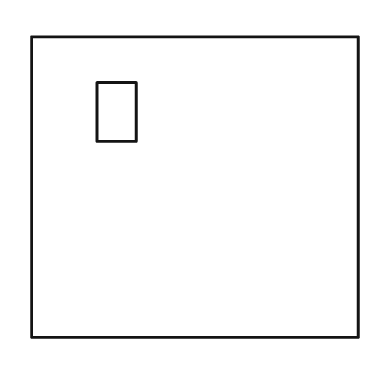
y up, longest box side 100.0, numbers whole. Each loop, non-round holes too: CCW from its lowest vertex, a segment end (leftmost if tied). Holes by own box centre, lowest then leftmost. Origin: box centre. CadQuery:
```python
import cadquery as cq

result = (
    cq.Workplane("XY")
    .moveTo(-50.0, -46.0)
    .lineTo(50.0, -46.0)
    .lineTo(50.0, 46.0)
    .lineTo(-50.0, 46.0)
    .close()
    .moveTo(-30.0, 14.0)
    .lineTo(-18.0, 14.0)
    .lineTo(-18.0, 32.0)
    .lineTo(-30.0, 32.0)
    .close()
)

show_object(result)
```